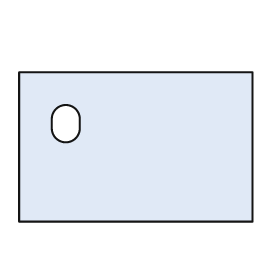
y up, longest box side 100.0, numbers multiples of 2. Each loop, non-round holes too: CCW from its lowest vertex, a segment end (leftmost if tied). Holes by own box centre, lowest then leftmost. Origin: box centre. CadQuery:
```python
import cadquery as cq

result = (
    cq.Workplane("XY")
    .moveTo(-50.0, -32.0)
    .lineTo(50.0, -32.0)
    .lineTo(50.0, 32.0)
    .lineTo(-50.0, 32.0)
    .close()
    .moveTo(-36.0, 8.0)
    .threePointArc((-30.0, 2.0), (-24.0, 8.0))
    .lineTo(-24.0, 12.0)
    .threePointArc((-30.0, 18.0), (-36.0, 12.0))
    .close()
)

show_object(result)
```